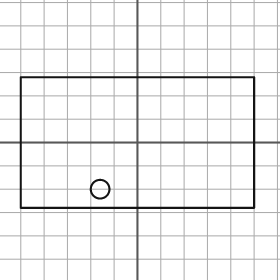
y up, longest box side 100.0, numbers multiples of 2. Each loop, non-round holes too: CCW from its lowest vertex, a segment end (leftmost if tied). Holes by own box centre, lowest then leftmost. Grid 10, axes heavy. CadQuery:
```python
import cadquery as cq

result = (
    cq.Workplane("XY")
    .moveTo(-50.0, -28.0)
    .lineTo(50.0, -28.0)
    .lineTo(50.0, 28.0)
    .lineTo(-50.0, 28.0)
    .close()
    .moveTo(-16.0, -20.0)
    .circle(4.0)
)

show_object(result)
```